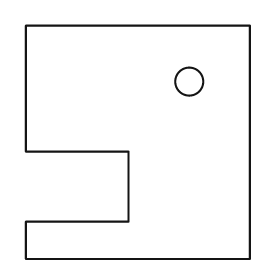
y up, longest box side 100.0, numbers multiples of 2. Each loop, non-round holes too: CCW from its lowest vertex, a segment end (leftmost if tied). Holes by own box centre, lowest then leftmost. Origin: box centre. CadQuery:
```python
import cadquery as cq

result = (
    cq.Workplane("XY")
    .moveTo(-48.0, -50.0)
    .lineTo(48.0, -50.0)
    .lineTo(48.0, 50.0)
    .lineTo(-48.0, 50.0)
    .lineTo(-48.0, -4.0)
    .lineTo(-4.0, -4.0)
    .lineTo(-4.0, -34.0)
    .lineTo(-48.0, -34.0)
    .close()
    .moveTo(22.0, 26.0)
    .circle(6.0)
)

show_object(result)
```